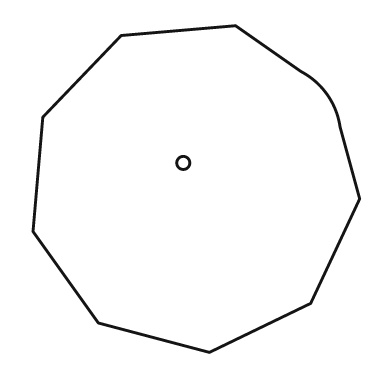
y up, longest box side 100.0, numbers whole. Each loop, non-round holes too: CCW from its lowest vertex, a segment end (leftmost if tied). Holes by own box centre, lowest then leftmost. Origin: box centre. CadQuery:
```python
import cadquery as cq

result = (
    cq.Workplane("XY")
    .moveTo(4.0, -50.0)
    .lineTo(35.0, -35.0)
    .lineTo(50.0, -3.0)
    .lineTo(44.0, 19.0)
    .threePointArc((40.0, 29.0), (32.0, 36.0))
    .lineTo(12.0, 50.0)
    .lineTo(-23.0, 47.0)
    .lineTo(-47.0, 22.0)
    .lineTo(-50.0, -13.0)
    .lineTo(-30.0, -41.0)
    .close()
    .moveTo(-4.0, 8.0)
    .circle(2.0)
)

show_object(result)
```